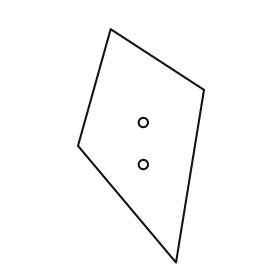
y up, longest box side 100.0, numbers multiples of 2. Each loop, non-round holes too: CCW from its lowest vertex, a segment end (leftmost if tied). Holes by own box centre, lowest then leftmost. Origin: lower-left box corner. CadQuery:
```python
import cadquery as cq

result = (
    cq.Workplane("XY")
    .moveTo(42.0, 0.0)
    .lineTo(54.0, 74.0)
    .lineTo(14.0, 100.0)
    .lineTo(0.0, 50.0)
    .close()
    .moveTo(28.0, 42.0)
    .circle(2.0)
    .moveTo(28.0, 60.0)
    .circle(2.0)
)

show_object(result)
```